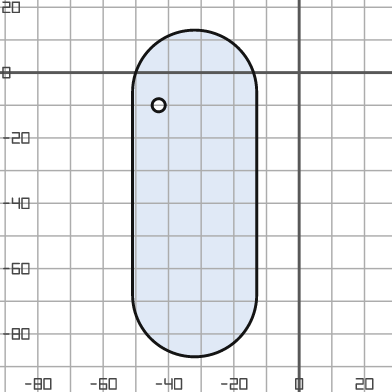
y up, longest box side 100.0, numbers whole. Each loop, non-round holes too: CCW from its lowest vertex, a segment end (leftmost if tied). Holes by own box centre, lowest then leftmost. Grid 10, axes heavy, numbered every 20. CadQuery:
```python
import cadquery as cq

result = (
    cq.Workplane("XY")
    .moveTo(-51.0, -68.0)
    .threePointArc((-32.0, -87.0), (-13.0, -68.0))
    .lineTo(-13.0, -6.0)
    .threePointArc((-32.0, 13.0), (-51.0, -6.0))
    .close()
    .moveTo(-43.0, -10.0)
    .circle(2.0)
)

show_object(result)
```